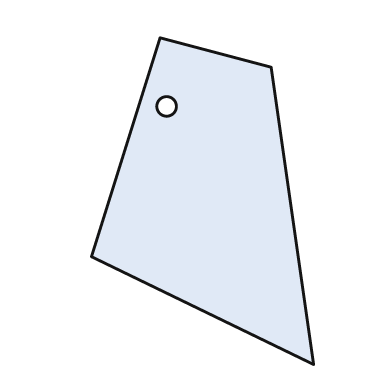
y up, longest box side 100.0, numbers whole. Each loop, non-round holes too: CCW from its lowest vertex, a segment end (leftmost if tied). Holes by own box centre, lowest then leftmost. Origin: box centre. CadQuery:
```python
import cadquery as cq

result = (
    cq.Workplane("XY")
    .moveTo(34.0, -50.0)
    .lineTo(21.0, 41.0)
    .lineTo(-13.0, 50.0)
    .lineTo(-34.0, -17.0)
    .close()
    .moveTo(-11.0, 29.0)
    .circle(3.0)
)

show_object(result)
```